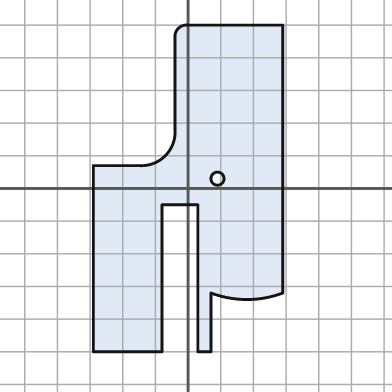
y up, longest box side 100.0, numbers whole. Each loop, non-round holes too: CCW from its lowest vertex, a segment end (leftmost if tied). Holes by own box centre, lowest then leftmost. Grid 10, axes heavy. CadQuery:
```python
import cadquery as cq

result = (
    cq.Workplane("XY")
    .moveTo(-29.0, -50.0)
    .lineTo(-8.0, -50.0)
    .lineTo(-8.0, -5.0)
    .lineTo(3.0, -5.0)
    .lineTo(3.0, -50.0)
    .lineTo(7.0, -50.0)
    .lineTo(7.0, -32.0)
    .threePointArc((18.0, -34.0), (29.0, -32.0))
    .lineTo(29.0, 50.0)
    .lineTo(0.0, 50.0)
    .threePointArc((-3.0, 49.0), (-4.0, 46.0))
    .lineTo(-4.0, 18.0)
    .threePointArc((-7.0, 10.0), (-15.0, 7.0))
    .lineTo(-29.0, 7.0)
    .close()
    .moveTo(9.0, 3.0)
    .circle(2.0)
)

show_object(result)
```